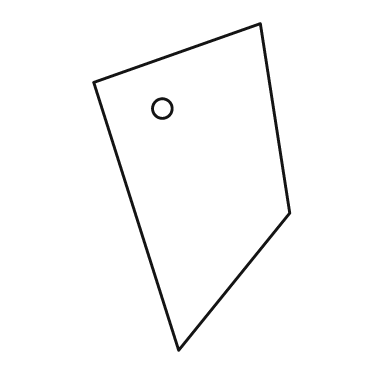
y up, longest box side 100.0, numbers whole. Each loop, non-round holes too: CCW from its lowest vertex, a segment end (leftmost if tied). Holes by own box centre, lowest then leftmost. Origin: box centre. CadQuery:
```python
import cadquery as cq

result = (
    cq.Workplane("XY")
    .moveTo(-4.0, -50.0)
    .lineTo(30.0, -8.0)
    .lineTo(21.0, 50.0)
    .lineTo(-30.0, 32.0)
    .close()
    .moveTo(-9.0, 24.0)
    .circle(3.0)
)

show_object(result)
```